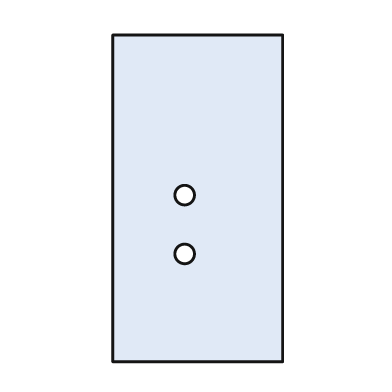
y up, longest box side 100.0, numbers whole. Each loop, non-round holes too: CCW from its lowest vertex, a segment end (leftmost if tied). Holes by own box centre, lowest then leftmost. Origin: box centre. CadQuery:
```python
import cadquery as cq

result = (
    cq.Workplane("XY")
    .moveTo(-26.0, -50.0)
    .lineTo(26.0, -50.0)
    .lineTo(26.0, 50.0)
    .lineTo(-26.0, 50.0)
    .close()
    .moveTo(-4.0, -17.0)
    .circle(3.0)
    .moveTo(-4.0, 1.0)
    .circle(3.0)
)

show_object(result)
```